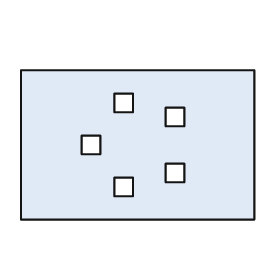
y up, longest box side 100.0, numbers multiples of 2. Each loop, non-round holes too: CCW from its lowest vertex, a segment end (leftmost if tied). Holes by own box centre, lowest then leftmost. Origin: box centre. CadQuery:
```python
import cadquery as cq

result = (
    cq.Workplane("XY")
    .moveTo(-50.0, -32.0)
    .lineTo(50.0, -32.0)
    .lineTo(50.0, 32.0)
    .lineTo(-50.0, 32.0)
    .close()
    .moveTo(-10.0, -22.0)
    .lineTo(-2.0, -22.0)
    .lineTo(-2.0, -14.0)
    .lineTo(-10.0, -14.0)
    .close()
    .moveTo(12.0, -16.0)
    .lineTo(20.0, -16.0)
    .lineTo(20.0, -8.0)
    .lineTo(12.0, -8.0)
    .close()
    .moveTo(-24.0, -4.0)
    .lineTo(-16.0, -4.0)
    .lineTo(-16.0, 4.0)
    .lineTo(-24.0, 4.0)
    .close()
    .moveTo(12.0, 8.0)
    .lineTo(20.0, 8.0)
    .lineTo(20.0, 16.0)
    .lineTo(12.0, 16.0)
    .close()
    .moveTo(-10.0, 14.0)
    .lineTo(-2.0, 14.0)
    .lineTo(-2.0, 22.0)
    .lineTo(-10.0, 22.0)
    .close()
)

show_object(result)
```